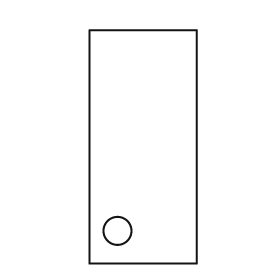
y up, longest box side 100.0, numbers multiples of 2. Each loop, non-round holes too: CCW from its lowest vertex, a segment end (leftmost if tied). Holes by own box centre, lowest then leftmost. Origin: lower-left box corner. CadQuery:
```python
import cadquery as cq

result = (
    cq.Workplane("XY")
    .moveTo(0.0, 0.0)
    .lineTo(46.0, 0.0)
    .lineTo(46.0, 100.0)
    .lineTo(0.0, 100.0)
    .close()
    .moveTo(12.0, 14.0)
    .circle(6.0)
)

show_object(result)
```